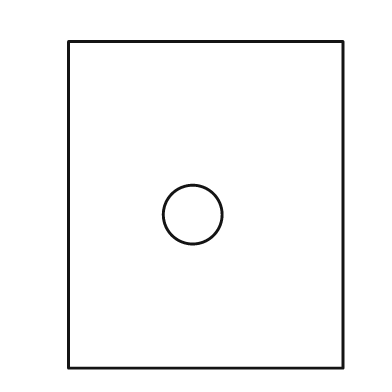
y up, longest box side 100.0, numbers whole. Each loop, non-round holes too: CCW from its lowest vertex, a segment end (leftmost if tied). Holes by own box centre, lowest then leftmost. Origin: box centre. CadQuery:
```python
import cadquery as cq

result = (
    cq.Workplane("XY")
    .moveTo(-42.0, -50.0)
    .lineTo(42.0, -50.0)
    .lineTo(42.0, 50.0)
    .lineTo(-42.0, 50.0)
    .close()
    .moveTo(-4.0, -3.0)
    .circle(9.0)
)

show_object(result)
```